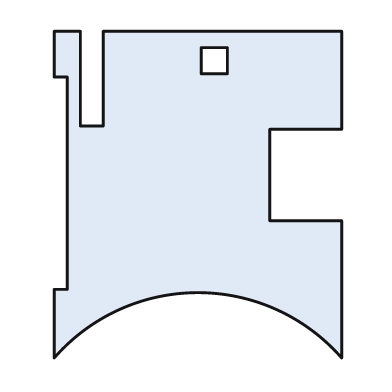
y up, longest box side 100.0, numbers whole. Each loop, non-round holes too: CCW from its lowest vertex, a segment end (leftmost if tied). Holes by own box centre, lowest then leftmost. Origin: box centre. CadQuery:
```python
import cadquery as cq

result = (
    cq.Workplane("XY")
    .moveTo(-44.0, -50.0)
    .threePointArc((0.0, -30.0), (44.0, -50.0))
    .lineTo(44.0, -8.0)
    .lineTo(22.0, -8.0)
    .lineTo(22.0, 20.0)
    .lineTo(44.0, 20.0)
    .lineTo(44.0, 50.0)
    .lineTo(-29.0, 50.0)
    .lineTo(-29.0, 21.0)
    .lineTo(-36.0, 21.0)
    .lineTo(-36.0, 50.0)
    .lineTo(-44.0, 50.0)
    .lineTo(-44.0, 36.0)
    .lineTo(-40.0, 36.0)
    .lineTo(-40.0, -29.0)
    .lineTo(-44.0, -29.0)
    .close()
    .moveTo(1.0, 37.0)
    .lineTo(9.0, 37.0)
    .lineTo(9.0, 45.0)
    .lineTo(1.0, 45.0)
    .close()
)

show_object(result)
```